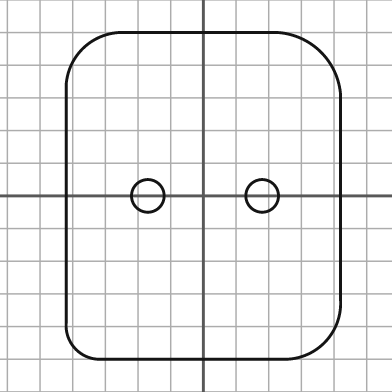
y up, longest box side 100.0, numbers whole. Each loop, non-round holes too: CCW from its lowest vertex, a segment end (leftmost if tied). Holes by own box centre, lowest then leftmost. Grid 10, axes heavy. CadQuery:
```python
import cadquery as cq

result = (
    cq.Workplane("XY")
    .moveTo(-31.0, -50.0)
    .lineTo(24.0, -50.0)
    .threePointArc((37.0, -45.0), (42.0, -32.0))
    .lineTo(42.0, 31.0)
    .threePointArc((36.0, 44.0), (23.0, 50.0))
    .lineTo(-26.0, 50.0)
    .threePointArc((-37.0, 45.0), (-42.0, 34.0))
    .lineTo(-42.0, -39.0)
    .threePointArc((-39.0, -47.0), (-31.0, -50.0))
    .close()
    .moveTo(-17.0, 0.0)
    .circle(5.0)
    .moveTo(18.0, 0.0)
    .circle(5.0)
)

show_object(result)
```